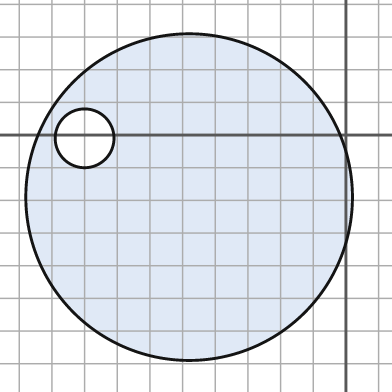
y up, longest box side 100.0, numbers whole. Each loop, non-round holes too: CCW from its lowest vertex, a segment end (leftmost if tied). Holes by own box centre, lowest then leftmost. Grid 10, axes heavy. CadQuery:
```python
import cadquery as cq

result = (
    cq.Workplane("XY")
    .moveTo(-48.0, -19.0)
    .circle(50.0)
    .moveTo(-80.0, -1.0)
    .circle(9.0)
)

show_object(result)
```